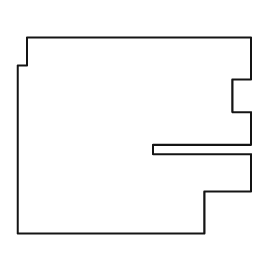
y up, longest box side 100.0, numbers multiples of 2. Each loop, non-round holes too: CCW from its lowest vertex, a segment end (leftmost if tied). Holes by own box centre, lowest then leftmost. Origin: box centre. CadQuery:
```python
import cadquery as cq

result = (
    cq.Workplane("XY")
    .moveTo(-50.0, -42.0)
    .lineTo(30.0, -42.0)
    .lineTo(30.0, -24.0)
    .lineTo(50.0, -24.0)
    .lineTo(50.0, -8.0)
    .lineTo(8.0, -8.0)
    .lineTo(8.0, -4.0)
    .lineTo(50.0, -4.0)
    .lineTo(50.0, 10.0)
    .lineTo(42.0, 10.0)
    .lineTo(42.0, 24.0)
    .lineTo(50.0, 24.0)
    .lineTo(50.0, 42.0)
    .lineTo(-46.0, 42.0)
    .lineTo(-46.0, 30.0)
    .lineTo(-50.0, 30.0)
    .close()
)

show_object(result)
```